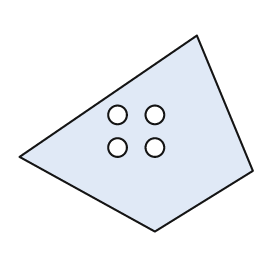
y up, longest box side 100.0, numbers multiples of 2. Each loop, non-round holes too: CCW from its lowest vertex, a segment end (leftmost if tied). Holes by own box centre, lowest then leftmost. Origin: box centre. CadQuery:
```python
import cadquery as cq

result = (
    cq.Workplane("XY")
    .moveTo(8.0, -42.0)
    .lineTo(50.0, -16.0)
    .lineTo(26.0, 42.0)
    .lineTo(-50.0, -10.0)
    .close()
    .moveTo(-8.0, -6.0)
    .circle(4.0)
    .moveTo(8.0, -6.0)
    .circle(4.0)
    .moveTo(-8.0, 8.0)
    .circle(4.0)
    .moveTo(8.0, 8.0)
    .circle(4.0)
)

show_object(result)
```